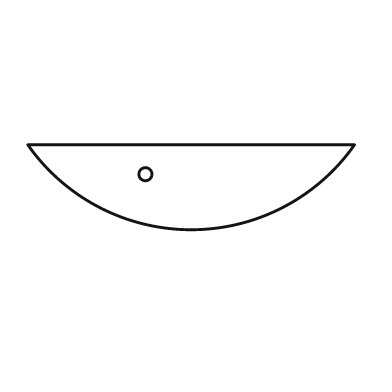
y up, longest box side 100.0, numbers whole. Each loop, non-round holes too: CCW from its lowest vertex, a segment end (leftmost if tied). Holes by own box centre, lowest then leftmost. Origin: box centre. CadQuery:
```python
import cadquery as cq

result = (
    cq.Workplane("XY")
    .moveTo(-50.0, 13.0)
    .threePointArc((0.0, -13.0), (50.0, 13.0))
    .close()
    .moveTo(-14.0, 4.0)
    .circle(2.0)
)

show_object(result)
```